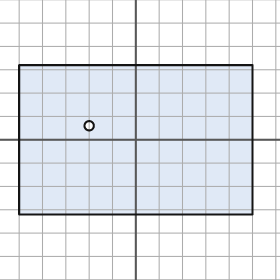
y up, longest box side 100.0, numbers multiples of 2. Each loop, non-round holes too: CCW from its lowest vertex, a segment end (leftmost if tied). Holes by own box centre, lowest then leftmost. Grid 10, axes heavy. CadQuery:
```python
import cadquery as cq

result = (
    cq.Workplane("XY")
    .moveTo(-50.0, -32.0)
    .lineTo(50.0, -32.0)
    .lineTo(50.0, 32.0)
    .lineTo(-50.0, 32.0)
    .close()
    .moveTo(-20.0, 6.0)
    .circle(2.0)
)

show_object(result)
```